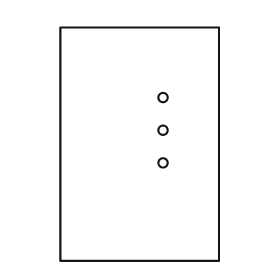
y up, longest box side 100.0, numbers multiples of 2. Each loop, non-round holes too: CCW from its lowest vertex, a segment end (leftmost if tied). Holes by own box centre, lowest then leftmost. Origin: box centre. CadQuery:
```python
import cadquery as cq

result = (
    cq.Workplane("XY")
    .moveTo(-34.0, -50.0)
    .lineTo(34.0, -50.0)
    .lineTo(34.0, 50.0)
    .lineTo(-34.0, 50.0)
    .close()
    .moveTo(10.0, -8.0)
    .circle(2.0)
    .moveTo(10.0, 6.0)
    .circle(2.0)
    .moveTo(10.0, 20.0)
    .circle(2.0)
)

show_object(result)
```